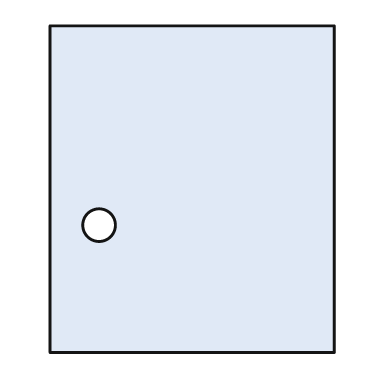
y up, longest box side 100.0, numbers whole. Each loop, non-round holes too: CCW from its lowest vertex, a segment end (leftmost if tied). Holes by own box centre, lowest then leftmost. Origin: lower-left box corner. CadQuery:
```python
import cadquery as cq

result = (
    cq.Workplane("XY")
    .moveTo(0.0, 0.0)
    .lineTo(87.0, 0.0)
    .lineTo(87.0, 100.0)
    .lineTo(0.0, 100.0)
    .close()
    .moveTo(15.0, 39.0)
    .circle(5.0)
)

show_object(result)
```